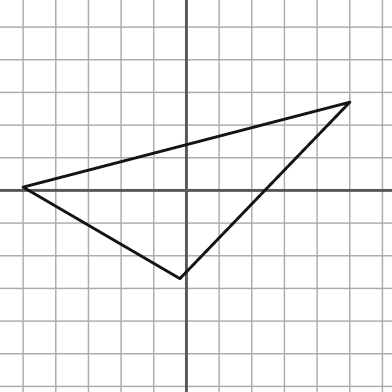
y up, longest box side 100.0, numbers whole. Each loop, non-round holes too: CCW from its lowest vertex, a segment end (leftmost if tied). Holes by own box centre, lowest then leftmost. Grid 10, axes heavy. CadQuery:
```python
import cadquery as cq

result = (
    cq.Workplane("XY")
    .moveTo(-2.0, -27.0)
    .lineTo(50.0, 27.0)
    .lineTo(-50.0, 1.0)
    .close()
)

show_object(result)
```